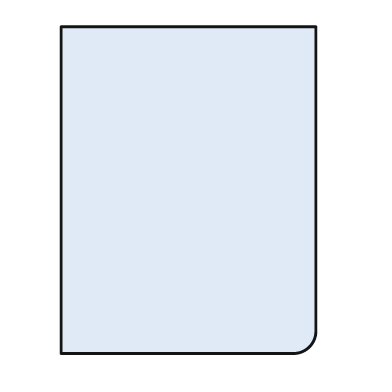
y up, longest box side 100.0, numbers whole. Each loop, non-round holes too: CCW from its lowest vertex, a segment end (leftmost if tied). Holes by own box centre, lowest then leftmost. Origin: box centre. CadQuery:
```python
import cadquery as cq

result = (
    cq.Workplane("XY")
    .moveTo(-39.0, -50.0)
    .lineTo(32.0, -50.0)
    .threePointArc((37.0, -48.0), (39.0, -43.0))
    .lineTo(39.0, 50.0)
    .lineTo(-39.0, 50.0)
    .close()
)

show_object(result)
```